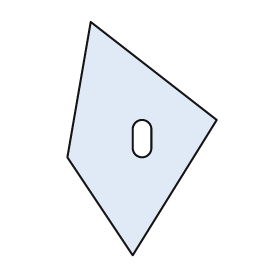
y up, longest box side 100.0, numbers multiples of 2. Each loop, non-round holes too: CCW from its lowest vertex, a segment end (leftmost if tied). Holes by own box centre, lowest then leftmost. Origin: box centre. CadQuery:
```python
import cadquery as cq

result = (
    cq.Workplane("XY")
    .moveTo(-4.0, -50.0)
    .lineTo(32.0, 8.0)
    .lineTo(-22.0, 50.0)
    .lineTo(-32.0, -8.0)
    .close()
    .moveTo(-4.0, -4.0)
    .threePointArc((0.0, -8.0), (4.0, -4.0))
    .lineTo(4.0, 4.0)
    .threePointArc((0.0, 8.0), (-4.0, 4.0))
    .close()
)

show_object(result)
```